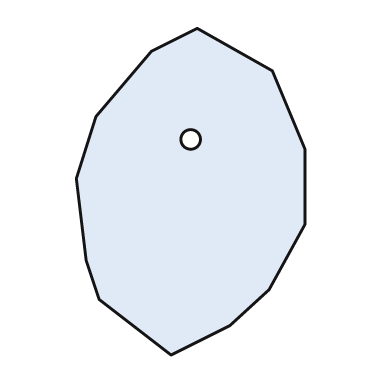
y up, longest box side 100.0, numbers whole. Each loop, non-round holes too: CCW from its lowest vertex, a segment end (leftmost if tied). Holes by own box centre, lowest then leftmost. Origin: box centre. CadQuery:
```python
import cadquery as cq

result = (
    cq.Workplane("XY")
    .moveTo(-6.0, -50.0)
    .lineTo(12.0, -41.0)
    .lineTo(24.0, -30.0)
    .lineTo(35.0, -10.0)
    .lineTo(35.0, 13.0)
    .lineTo(25.0, 37.0)
    .lineTo(2.0, 50.0)
    .lineTo(-12.0, 43.0)
    .lineTo(-29.0, 23.0)
    .lineTo(-35.0, 4.0)
    .lineTo(-32.0, -21.0)
    .lineTo(-28.0, -33.0)
    .close()
    .moveTo(0.0, 16.0)
    .circle(3.0)
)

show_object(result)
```